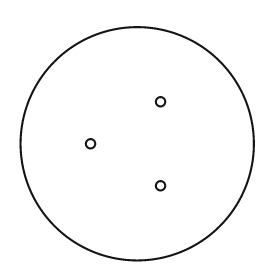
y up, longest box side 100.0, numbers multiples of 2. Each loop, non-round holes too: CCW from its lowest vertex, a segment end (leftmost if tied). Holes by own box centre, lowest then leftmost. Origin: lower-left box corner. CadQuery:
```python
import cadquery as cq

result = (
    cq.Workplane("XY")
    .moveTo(50.0, 50.0)
    .circle(50.0)
    .moveTo(60.0, 32.0)
    .circle(2.0)
    .moveTo(30.0, 50.0)
    .circle(2.0)
    .moveTo(60.0, 68.0)
    .circle(2.0)
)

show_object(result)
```